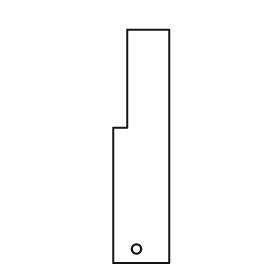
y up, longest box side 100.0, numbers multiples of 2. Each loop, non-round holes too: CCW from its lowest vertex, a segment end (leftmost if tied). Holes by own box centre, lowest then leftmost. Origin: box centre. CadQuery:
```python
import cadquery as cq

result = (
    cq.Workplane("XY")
    .moveTo(-12.0, -50.0)
    .lineTo(12.0, -50.0)
    .lineTo(12.0, 50.0)
    .lineTo(-6.0, 50.0)
    .lineTo(-6.0, 8.0)
    .lineTo(-12.0, 8.0)
    .close()
    .moveTo(-2.0, -44.0)
    .circle(2.0)
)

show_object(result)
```